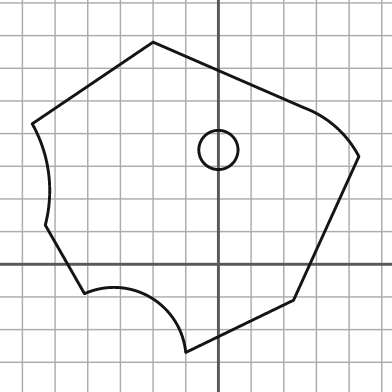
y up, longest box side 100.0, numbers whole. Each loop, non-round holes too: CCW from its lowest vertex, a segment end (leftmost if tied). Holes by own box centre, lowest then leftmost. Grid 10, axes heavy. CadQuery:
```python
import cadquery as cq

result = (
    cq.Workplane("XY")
    .moveTo(-10.0, -27.0)
    .lineTo(23.0, -11.0)
    .lineTo(43.0, 33.0)
    .threePointArc((36.0, 42.0), (26.0, 48.0))
    .lineTo(-20.0, 68.0)
    .lineTo(-57.0, 43.0)
    .threePointArc((-52.0, 28.0), (-53.0, 12.0))
    .lineTo(-41.0, -9.0)
    .threePointArc((-21.0, -10.0), (-10.0, -27.0))
    .close()
    .moveTo(0.0, 35.0)
    .circle(6.0)
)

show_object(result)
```